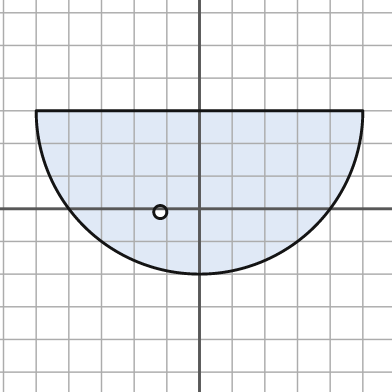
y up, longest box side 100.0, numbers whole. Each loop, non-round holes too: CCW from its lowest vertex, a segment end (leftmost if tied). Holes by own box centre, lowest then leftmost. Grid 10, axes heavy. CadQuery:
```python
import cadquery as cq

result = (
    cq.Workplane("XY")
    .moveTo(-50.0, 30.0)
    .threePointArc((0.0, -20.0), (50.0, 30.0))
    .close()
    .moveTo(-12.0, -1.0)
    .circle(2.0)
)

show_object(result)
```